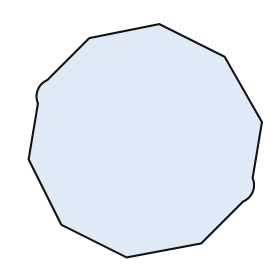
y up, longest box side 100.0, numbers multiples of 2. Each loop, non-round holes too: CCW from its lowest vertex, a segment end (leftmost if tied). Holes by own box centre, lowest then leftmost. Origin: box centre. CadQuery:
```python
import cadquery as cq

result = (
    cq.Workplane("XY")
    .moveTo(-8.0, -50.0)
    .lineTo(24.0, -44.0)
    .lineTo(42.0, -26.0)
    .threePointArc((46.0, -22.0), (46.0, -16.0))
    .lineTo(50.0, 8.0)
    .lineTo(34.0, 36.0)
    .lineTo(6.0, 50.0)
    .lineTo(-24.0, 44.0)
    .lineTo(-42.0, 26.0)
    .threePointArc((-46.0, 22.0), (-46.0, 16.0))
    .lineTo(-50.0, -8.0)
    .lineTo(-36.0, -36.0)
    .close()
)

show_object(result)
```